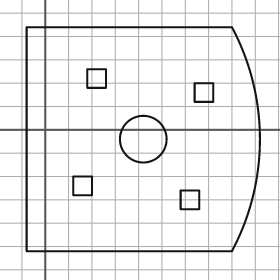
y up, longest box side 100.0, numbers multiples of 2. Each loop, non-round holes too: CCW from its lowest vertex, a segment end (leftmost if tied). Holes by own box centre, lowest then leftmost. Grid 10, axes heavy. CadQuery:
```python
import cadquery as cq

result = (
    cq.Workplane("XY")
    .moveTo(-8.0, -52.0)
    .lineTo(80.0, -52.0)
    .threePointArc((92.0, -4.0), (80.0, 44.0))
    .lineTo(-8.0, 44.0)
    .close()
    .moveTo(58.0, -34.0)
    .lineTo(66.0, -34.0)
    .lineTo(66.0, -26.0)
    .lineTo(58.0, -26.0)
    .close()
    .moveTo(12.0, -28.0)
    .lineTo(20.0, -28.0)
    .lineTo(20.0, -20.0)
    .lineTo(12.0, -20.0)
    .close()
    .moveTo(42.0, -4.0)
    .circle(10.0)
    .moveTo(64.0, 12.0)
    .lineTo(72.0, 12.0)
    .lineTo(72.0, 20.0)
    .lineTo(64.0, 20.0)
    .close()
    .moveTo(18.0, 18.0)
    .lineTo(26.0, 18.0)
    .lineTo(26.0, 26.0)
    .lineTo(18.0, 26.0)
    .close()
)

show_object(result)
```